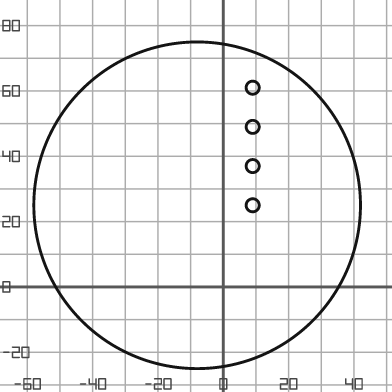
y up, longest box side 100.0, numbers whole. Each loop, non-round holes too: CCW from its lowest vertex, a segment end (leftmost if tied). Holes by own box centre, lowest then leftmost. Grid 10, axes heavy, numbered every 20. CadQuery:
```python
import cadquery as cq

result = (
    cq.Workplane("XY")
    .moveTo(-8.0, 25.0)
    .circle(50.0)
    .moveTo(9.0, 25.0)
    .circle(2.0)
    .moveTo(9.0, 37.0)
    .circle(2.0)
    .moveTo(9.0, 49.0)
    .circle(2.0)
    .moveTo(9.0, 61.0)
    .circle(2.0)
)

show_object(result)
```